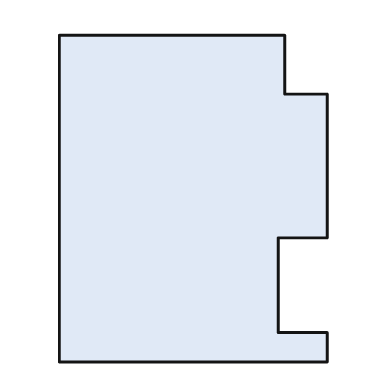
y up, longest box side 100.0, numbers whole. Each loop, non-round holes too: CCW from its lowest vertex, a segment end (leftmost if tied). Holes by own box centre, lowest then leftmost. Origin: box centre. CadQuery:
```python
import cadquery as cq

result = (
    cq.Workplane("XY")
    .moveTo(-41.0, -50.0)
    .lineTo(41.0, -50.0)
    .lineTo(41.0, -41.0)
    .lineTo(26.0, -41.0)
    .lineTo(26.0, -12.0)
    .lineTo(41.0, -12.0)
    .lineTo(41.0, 32.0)
    .lineTo(28.0, 32.0)
    .lineTo(28.0, 50.0)
    .lineTo(-41.0, 50.0)
    .close()
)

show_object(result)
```